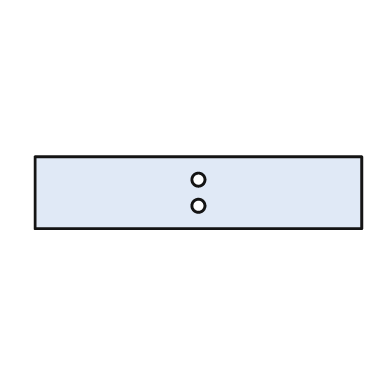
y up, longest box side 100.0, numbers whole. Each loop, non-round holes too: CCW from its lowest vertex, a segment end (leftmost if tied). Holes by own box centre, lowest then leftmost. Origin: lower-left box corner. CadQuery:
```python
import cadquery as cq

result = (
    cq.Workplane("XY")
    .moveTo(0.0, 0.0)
    .lineTo(100.0, 0.0)
    .lineTo(100.0, 22.0)
    .lineTo(0.0, 22.0)
    .close()
    .moveTo(50.0, 7.0)
    .circle(2.0)
    .moveTo(50.0, 15.0)
    .circle(2.0)
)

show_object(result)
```